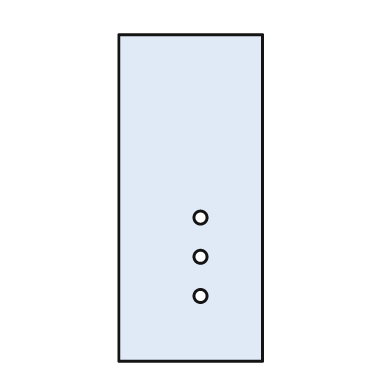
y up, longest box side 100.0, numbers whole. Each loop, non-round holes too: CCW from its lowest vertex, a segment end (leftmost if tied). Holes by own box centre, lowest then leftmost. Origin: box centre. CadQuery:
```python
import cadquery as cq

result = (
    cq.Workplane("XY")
    .moveTo(-22.0, -50.0)
    .lineTo(22.0, -50.0)
    .lineTo(22.0, 50.0)
    .lineTo(-22.0, 50.0)
    .close()
    .moveTo(3.0, -30.0)
    .circle(2.0)
    .moveTo(3.0, -18.0)
    .circle(2.0)
    .moveTo(3.0, -6.0)
    .circle(2.0)
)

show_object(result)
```